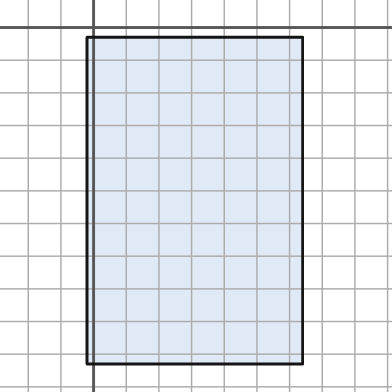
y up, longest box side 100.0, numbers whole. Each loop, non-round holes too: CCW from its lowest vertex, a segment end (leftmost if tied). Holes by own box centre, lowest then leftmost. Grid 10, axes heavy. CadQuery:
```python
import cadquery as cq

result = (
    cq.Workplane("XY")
    .moveTo(-2.0, -103.0)
    .lineTo(64.0, -103.0)
    .lineTo(64.0, -3.0)
    .lineTo(-2.0, -3.0)
    .close()
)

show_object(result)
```